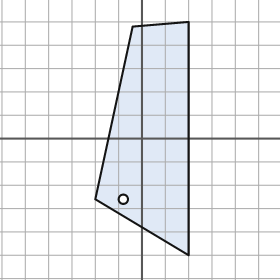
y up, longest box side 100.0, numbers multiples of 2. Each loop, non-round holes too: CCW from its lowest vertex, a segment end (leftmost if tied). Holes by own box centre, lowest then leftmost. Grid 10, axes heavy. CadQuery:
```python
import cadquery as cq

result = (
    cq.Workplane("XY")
    .moveTo(20.0, -50.0)
    .lineTo(20.0, 50.0)
    .lineTo(-4.0, 48.0)
    .lineTo(-20.0, -26.0)
    .close()
    .moveTo(-8.0, -26.0)
    .circle(2.0)
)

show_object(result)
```